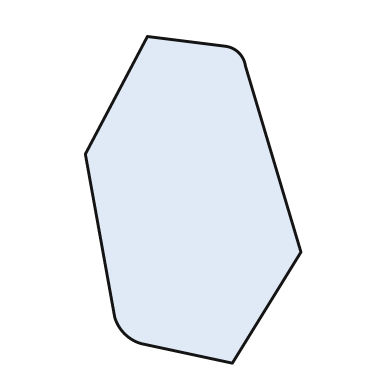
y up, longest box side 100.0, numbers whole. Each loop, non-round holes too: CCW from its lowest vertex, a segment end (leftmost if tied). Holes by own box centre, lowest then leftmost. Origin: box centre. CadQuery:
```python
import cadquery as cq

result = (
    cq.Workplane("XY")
    .moveTo(12.0, -50.0)
    .lineTo(33.0, -16.0)
    .lineTo(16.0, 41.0)
    .threePointArc((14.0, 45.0), (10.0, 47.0))
    .lineTo(-14.0, 50.0)
    .lineTo(-33.0, 14.0)
    .lineTo(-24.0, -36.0)
    .threePointArc((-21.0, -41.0), (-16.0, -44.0))
    .close()
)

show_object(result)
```